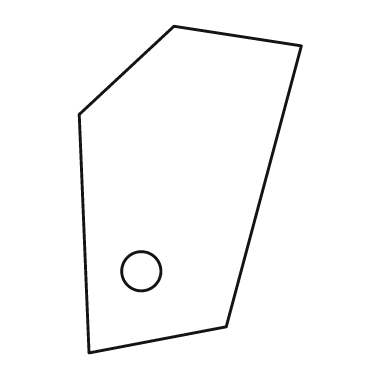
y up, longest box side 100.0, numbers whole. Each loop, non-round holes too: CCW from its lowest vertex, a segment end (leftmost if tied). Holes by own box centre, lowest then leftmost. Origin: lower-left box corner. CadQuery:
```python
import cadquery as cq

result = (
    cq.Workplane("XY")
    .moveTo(3.0, 0.0)
    .lineTo(45.0, 8.0)
    .lineTo(68.0, 94.0)
    .lineTo(29.0, 100.0)
    .lineTo(0.0, 73.0)
    .close()
    .moveTo(19.0, 25.0)
    .circle(6.0)
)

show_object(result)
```